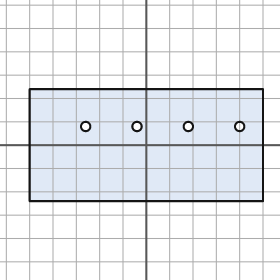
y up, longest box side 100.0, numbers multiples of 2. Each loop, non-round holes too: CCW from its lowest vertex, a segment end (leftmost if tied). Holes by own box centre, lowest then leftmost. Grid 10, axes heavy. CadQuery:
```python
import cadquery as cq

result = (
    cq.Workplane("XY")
    .moveTo(-50.0, -24.0)
    .lineTo(50.0, -24.0)
    .lineTo(50.0, 24.0)
    .lineTo(-50.0, 24.0)
    .close()
    .moveTo(-26.0, 8.0)
    .circle(2.0)
    .moveTo(-4.0, 8.0)
    .circle(2.0)
    .moveTo(18.0, 8.0)
    .circle(2.0)
    .moveTo(40.0, 8.0)
    .circle(2.0)
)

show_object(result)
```